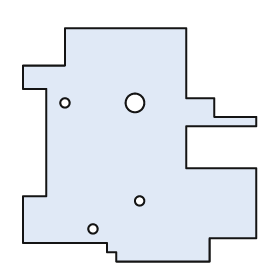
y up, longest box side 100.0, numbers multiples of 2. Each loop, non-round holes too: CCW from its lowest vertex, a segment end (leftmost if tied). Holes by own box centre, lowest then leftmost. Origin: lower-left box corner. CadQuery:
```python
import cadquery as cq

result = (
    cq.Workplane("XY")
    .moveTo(40.0, 0.0)
    .lineTo(80.0, 0.0)
    .lineTo(80.0, 10.0)
    .lineTo(100.0, 10.0)
    .lineTo(100.0, 40.0)
    .lineTo(70.0, 40.0)
    .lineTo(70.0, 58.0)
    .lineTo(100.0, 58.0)
    .lineTo(100.0, 62.0)
    .lineTo(82.0, 62.0)
    .lineTo(82.0, 70.0)
    .lineTo(70.0, 70.0)
    .lineTo(70.0, 100.0)
    .lineTo(18.0, 100.0)
    .lineTo(18.0, 84.0)
    .lineTo(0.0, 84.0)
    .lineTo(0.0, 74.0)
    .lineTo(10.0, 74.0)
    .lineTo(10.0, 28.0)
    .lineTo(0.0, 28.0)
    .lineTo(0.0, 8.0)
    .lineTo(36.0, 8.0)
    .lineTo(36.0, 4.0)
    .lineTo(40.0, 4.0)
    .close()
    .moveTo(30.0, 14.0)
    .circle(2.0)
    .moveTo(50.0, 26.0)
    .circle(2.0)
    .moveTo(18.0, 68.0)
    .circle(2.0)
    .moveTo(48.0, 68.0)
    .circle(4.0)
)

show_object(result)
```